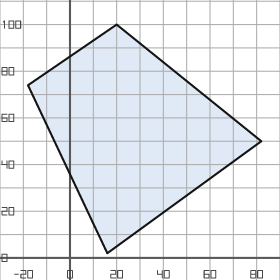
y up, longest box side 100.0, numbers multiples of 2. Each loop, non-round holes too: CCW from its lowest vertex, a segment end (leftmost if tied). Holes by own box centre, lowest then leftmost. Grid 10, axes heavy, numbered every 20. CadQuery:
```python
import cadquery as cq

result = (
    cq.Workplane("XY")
    .moveTo(16.0, 2.0)
    .lineTo(82.0, 50.0)
    .lineTo(20.0, 100.0)
    .lineTo(-18.0, 74.0)
    .close()
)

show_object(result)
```